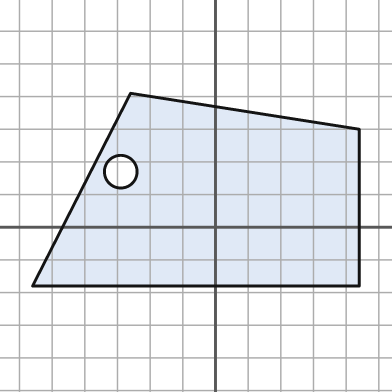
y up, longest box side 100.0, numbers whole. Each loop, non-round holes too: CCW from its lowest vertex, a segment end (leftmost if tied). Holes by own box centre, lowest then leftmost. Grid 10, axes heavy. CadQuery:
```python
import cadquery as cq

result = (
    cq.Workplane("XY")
    .moveTo(-56.0, -18.0)
    .lineTo(44.0, -18.0)
    .lineTo(44.0, 30.0)
    .lineTo(-26.0, 41.0)
    .close()
    .moveTo(-29.0, 17.0)
    .circle(5.0)
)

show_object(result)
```